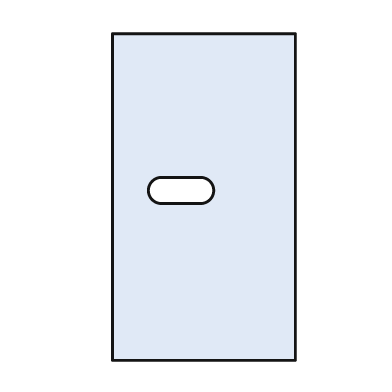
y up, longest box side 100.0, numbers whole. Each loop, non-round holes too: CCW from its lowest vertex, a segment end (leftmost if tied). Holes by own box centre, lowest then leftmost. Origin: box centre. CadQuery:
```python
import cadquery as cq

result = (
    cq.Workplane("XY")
    .moveTo(-28.0, -50.0)
    .lineTo(28.0, -50.0)
    .lineTo(28.0, 50.0)
    .lineTo(-28.0, 50.0)
    .close()
    .moveTo(-13.0, -2.0)
    .lineTo(-1.0, -2.0)
    .threePointArc((3.0, 2.0), (-1.0, 6.0))
    .lineTo(-13.0, 6.0)
    .threePointArc((-17.0, 2.0), (-13.0, -2.0))
    .close()
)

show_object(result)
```